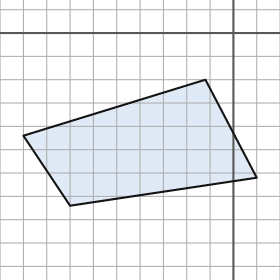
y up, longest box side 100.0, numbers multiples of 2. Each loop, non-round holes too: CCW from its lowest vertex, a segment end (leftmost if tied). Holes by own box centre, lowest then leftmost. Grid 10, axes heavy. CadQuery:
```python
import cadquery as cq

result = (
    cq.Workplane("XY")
    .moveTo(-70.0, -74.0)
    .lineTo(10.0, -62.0)
    .lineTo(-12.0, -20.0)
    .lineTo(-90.0, -44.0)
    .close()
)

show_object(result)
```